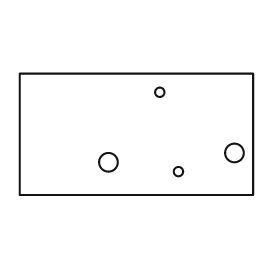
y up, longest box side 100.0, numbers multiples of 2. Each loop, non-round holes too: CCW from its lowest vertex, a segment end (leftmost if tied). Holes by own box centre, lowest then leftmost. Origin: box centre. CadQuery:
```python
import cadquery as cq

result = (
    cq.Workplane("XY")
    .moveTo(-50.0, -26.0)
    .lineTo(50.0, -26.0)
    .lineTo(50.0, 26.0)
    .lineTo(-50.0, 26.0)
    .close()
    .moveTo(18.0, -16.0)
    .circle(2.0)
    .moveTo(-12.0, -12.0)
    .circle(4.0)
    .moveTo(42.0, -8.0)
    .circle(4.0)
    .moveTo(10.0, 18.0)
    .circle(2.0)
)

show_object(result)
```